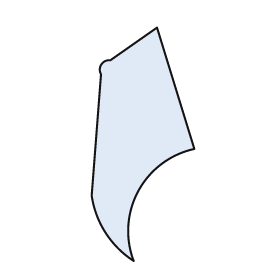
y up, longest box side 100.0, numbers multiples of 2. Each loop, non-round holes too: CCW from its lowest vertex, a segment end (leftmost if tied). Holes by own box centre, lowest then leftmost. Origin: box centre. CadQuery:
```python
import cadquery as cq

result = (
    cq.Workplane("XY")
    .moveTo(-4.0, -50.0)
    .threePointArc((-2.0, -20.0), (22.0, -2.0))
    .lineTo(6.0, 50.0)
    .lineTo(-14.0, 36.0)
    .threePointArc((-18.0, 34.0), (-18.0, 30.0))
    .lineTo(-22.0, -22.0)
    .threePointArc((-16.0, -38.0), (-4.0, -50.0))
    .close()
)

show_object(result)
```